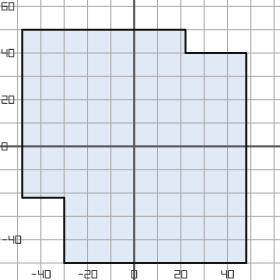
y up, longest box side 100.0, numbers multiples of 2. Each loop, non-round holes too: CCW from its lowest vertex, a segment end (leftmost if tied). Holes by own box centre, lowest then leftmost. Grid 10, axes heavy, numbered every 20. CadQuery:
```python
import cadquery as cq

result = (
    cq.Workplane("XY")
    .moveTo(-30.0, -50.0)
    .lineTo(48.0, -50.0)
    .lineTo(48.0, 40.0)
    .lineTo(22.0, 40.0)
    .lineTo(22.0, 50.0)
    .lineTo(-48.0, 50.0)
    .lineTo(-48.0, -22.0)
    .lineTo(-30.0, -22.0)
    .close()
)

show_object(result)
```